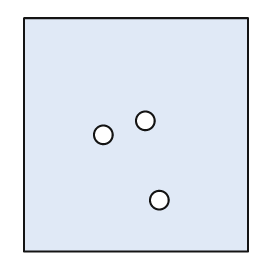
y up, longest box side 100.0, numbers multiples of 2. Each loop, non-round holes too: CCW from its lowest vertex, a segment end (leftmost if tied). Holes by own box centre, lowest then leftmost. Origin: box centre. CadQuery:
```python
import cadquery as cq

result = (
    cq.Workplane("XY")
    .moveTo(-48.0, -50.0)
    .lineTo(48.0, -50.0)
    .lineTo(48.0, 50.0)
    .lineTo(-48.0, 50.0)
    .close()
    .moveTo(10.0, -28.0)
    .circle(4.0)
    .moveTo(-14.0, 0.0)
    .circle(4.0)
    .moveTo(4.0, 6.0)
    .circle(4.0)
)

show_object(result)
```